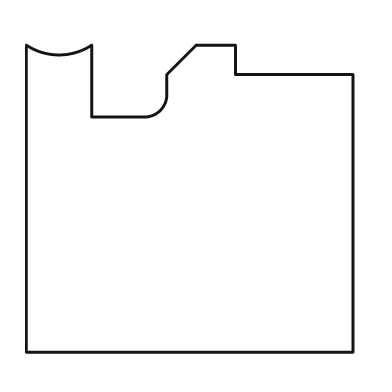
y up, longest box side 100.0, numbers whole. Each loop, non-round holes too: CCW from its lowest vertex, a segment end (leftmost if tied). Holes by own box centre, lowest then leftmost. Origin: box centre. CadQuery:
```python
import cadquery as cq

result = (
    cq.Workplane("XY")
    .moveTo(-50.0, -47.0)
    .lineTo(50.0, -47.0)
    .lineTo(50.0, 38.0)
    .lineTo(14.0, 38.0)
    .lineTo(14.0, 47.0)
    .lineTo(2.0, 47.0)
    .lineTo(-7.0, 38.0)
    .lineTo(-7.0, 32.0)
    .threePointArc((-9.0, 27.0), (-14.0, 25.0))
    .lineTo(-30.0, 25.0)
    .lineTo(-30.0, 47.0)
    .threePointArc((-40.0, 44.0), (-50.0, 47.0))
    .close()
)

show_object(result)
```